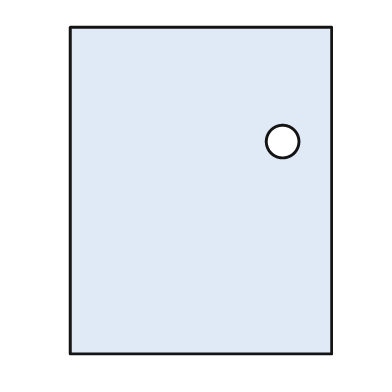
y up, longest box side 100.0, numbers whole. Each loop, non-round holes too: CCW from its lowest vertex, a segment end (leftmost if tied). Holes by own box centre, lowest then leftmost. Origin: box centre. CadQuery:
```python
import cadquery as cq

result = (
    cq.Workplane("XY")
    .moveTo(-40.0, -50.0)
    .lineTo(40.0, -50.0)
    .lineTo(40.0, 50.0)
    .lineTo(-40.0, 50.0)
    .close()
    .moveTo(25.0, 15.0)
    .circle(5.0)
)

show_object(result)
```